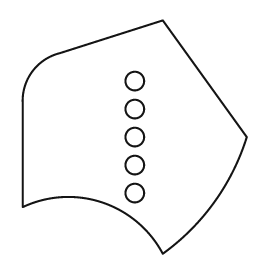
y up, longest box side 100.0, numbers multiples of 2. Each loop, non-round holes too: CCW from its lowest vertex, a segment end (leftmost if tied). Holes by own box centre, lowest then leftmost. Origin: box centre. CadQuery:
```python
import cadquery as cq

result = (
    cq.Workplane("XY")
    .moveTo(12.0, -50.0)
    .threePointArc((34.0, -28.0), (48.0, 0.0))
    .lineTo(12.0, 50.0)
    .lineTo(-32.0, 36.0)
    .threePointArc((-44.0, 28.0), (-48.0, 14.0))
    .lineTo(-48.0, -30.0)
    .threePointArc((-14.0, -28.0), (12.0, -50.0))
    .close()
    .moveTo(0.0, -24.0)
    .circle(4.0)
    .moveTo(0.0, -12.0)
    .circle(4.0)
    .moveTo(0.0, 0.0)
    .circle(4.0)
    .moveTo(0.0, 12.0)
    .circle(4.0)
    .moveTo(0.0, 24.0)
    .circle(4.0)
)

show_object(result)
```